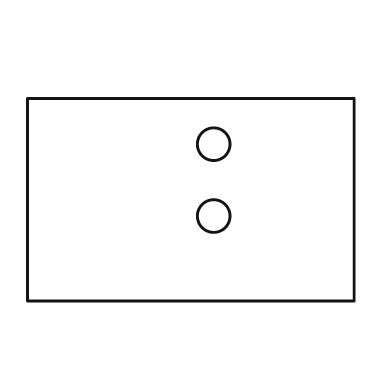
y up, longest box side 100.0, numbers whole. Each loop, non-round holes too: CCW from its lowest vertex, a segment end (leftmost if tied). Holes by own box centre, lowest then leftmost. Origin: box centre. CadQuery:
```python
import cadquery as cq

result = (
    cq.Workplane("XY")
    .moveTo(-50.0, -31.0)
    .lineTo(50.0, -31.0)
    .lineTo(50.0, 31.0)
    .lineTo(-50.0, 31.0)
    .close()
    .moveTo(7.0, -5.0)
    .circle(5.0)
    .moveTo(7.0, 17.0)
    .circle(5.0)
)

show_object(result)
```